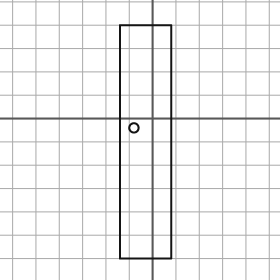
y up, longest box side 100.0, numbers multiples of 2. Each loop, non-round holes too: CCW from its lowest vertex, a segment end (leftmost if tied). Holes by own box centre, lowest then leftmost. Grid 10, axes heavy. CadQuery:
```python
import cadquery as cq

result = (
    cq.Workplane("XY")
    .moveTo(-14.0, -60.0)
    .lineTo(8.0, -60.0)
    .lineTo(8.0, 40.0)
    .lineTo(-14.0, 40.0)
    .close()
    .moveTo(-8.0, -4.0)
    .circle(2.0)
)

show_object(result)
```